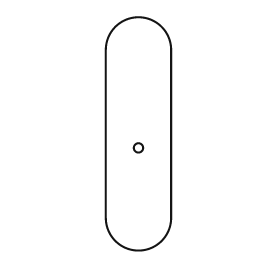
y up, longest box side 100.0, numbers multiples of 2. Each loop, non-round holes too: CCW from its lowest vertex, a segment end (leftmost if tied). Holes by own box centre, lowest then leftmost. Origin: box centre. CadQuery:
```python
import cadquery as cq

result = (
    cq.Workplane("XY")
    .moveTo(-14.0, -36.0)
    .threePointArc((0.0, -50.0), (14.0, -36.0))
    .lineTo(14.0, 36.0)
    .threePointArc((0.0, 50.0), (-14.0, 36.0))
    .close()
    .moveTo(0.0, -6.0)
    .circle(2.0)
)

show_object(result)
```